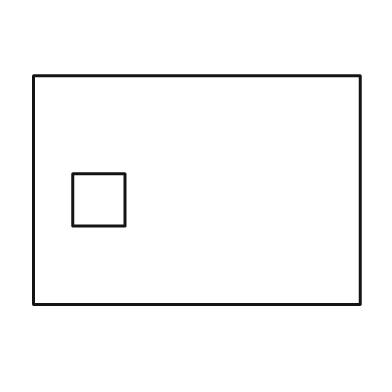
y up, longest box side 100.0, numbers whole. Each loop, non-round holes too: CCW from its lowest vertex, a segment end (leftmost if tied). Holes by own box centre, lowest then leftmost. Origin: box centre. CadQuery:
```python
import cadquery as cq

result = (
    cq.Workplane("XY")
    .moveTo(-50.0, -35.0)
    .lineTo(50.0, -35.0)
    .lineTo(50.0, 35.0)
    .lineTo(-50.0, 35.0)
    .close()
    .moveTo(-38.0, -11.0)
    .lineTo(-22.0, -11.0)
    .lineTo(-22.0, 5.0)
    .lineTo(-38.0, 5.0)
    .close()
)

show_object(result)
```